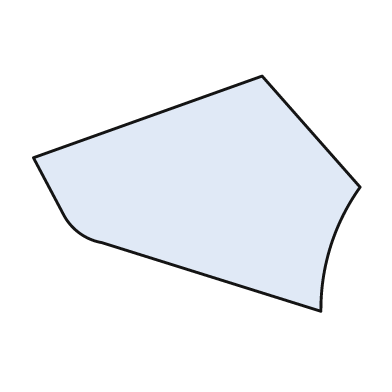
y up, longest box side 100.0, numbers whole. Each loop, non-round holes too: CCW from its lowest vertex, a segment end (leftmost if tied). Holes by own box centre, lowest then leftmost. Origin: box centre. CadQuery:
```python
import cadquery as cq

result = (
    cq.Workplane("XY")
    .moveTo(38.0, -36.0)
    .threePointArc((41.0, -16.0), (50.0, 2.0))
    .lineTo(20.0, 36.0)
    .lineTo(-50.0, 11.0)
    .lineTo(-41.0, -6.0)
    .threePointArc((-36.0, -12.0), (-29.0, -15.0))
    .close()
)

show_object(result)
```